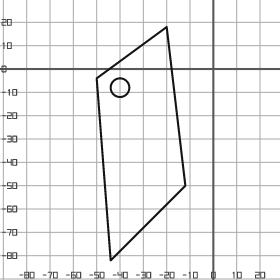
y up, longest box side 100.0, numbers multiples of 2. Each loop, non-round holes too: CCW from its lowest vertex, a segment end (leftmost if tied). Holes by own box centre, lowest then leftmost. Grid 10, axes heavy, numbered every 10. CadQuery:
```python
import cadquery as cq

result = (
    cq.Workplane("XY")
    .moveTo(-44.0, -82.0)
    .lineTo(-12.0, -50.0)
    .lineTo(-20.0, 18.0)
    .lineTo(-50.0, -4.0)
    .close()
    .moveTo(-40.0, -8.0)
    .circle(4.0)
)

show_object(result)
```